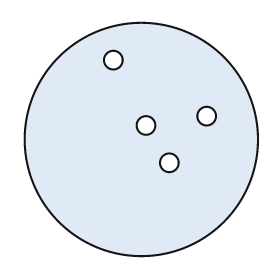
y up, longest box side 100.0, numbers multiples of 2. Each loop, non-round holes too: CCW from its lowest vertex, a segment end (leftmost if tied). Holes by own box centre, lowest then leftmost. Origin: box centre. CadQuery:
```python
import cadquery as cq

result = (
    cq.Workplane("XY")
    .moveTo(0.0, 0.0)
    .circle(50.0)
    .moveTo(12.0, -10.0)
    .circle(4.0)
    .moveTo(2.0, 6.0)
    .circle(4.0)
    .moveTo(28.0, 10.0)
    .circle(4.0)
    .moveTo(-12.0, 34.0)
    .circle(4.0)
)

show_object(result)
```